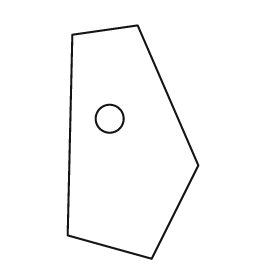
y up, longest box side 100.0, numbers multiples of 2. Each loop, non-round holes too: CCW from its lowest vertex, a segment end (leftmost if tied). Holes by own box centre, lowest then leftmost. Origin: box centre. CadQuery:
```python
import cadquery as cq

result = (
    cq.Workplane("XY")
    .moveTo(8.0, -50.0)
    .lineTo(28.0, -10.0)
    .lineTo(2.0, 50.0)
    .lineTo(-26.0, 46.0)
    .lineTo(-28.0, -40.0)
    .close()
    .moveTo(-10.0, 10.0)
    .circle(6.0)
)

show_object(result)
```